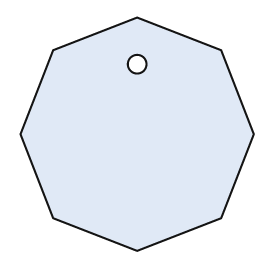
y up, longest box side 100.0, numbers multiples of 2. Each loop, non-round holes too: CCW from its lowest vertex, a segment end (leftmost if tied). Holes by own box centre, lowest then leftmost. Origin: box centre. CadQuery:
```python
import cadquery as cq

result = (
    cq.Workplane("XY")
    .moveTo(0.0, -50.0)
    .lineTo(36.0, -36.0)
    .lineTo(50.0, 0.0)
    .lineTo(36.0, 36.0)
    .lineTo(0.0, 50.0)
    .lineTo(-36.0, 36.0)
    .lineTo(-50.0, 0.0)
    .lineTo(-36.0, -36.0)
    .close()
    .moveTo(0.0, 30.0)
    .circle(4.0)
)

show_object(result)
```